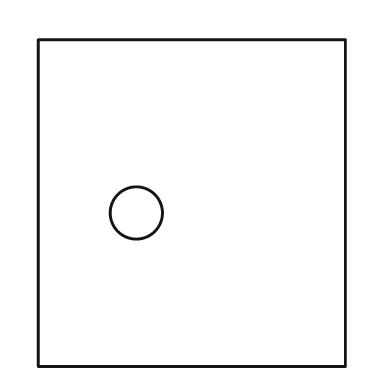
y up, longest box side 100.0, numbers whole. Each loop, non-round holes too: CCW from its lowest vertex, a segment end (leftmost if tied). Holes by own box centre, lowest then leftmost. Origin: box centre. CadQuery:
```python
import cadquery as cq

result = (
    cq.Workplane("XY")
    .moveTo(-47.0, -50.0)
    .lineTo(47.0, -50.0)
    .lineTo(47.0, 50.0)
    .lineTo(-47.0, 50.0)
    .close()
    .moveTo(-17.0, -3.0)
    .circle(8.0)
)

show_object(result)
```